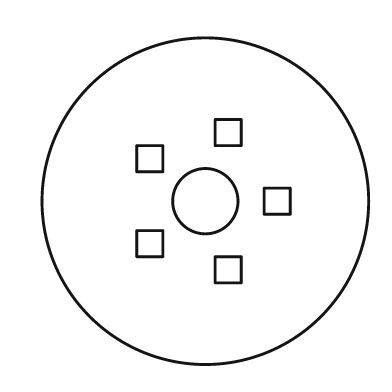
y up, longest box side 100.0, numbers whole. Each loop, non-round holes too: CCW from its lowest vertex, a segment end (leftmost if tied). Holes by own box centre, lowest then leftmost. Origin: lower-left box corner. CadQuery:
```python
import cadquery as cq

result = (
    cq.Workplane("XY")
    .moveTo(50.0, 50.0)
    .circle(50.0)
    .moveTo(53.0, 25.0)
    .lineTo(61.0, 25.0)
    .lineTo(61.0, 33.0)
    .lineTo(53.0, 33.0)
    .close()
    .moveTo(29.0, 33.0)
    .lineTo(37.0, 33.0)
    .lineTo(37.0, 41.0)
    .lineTo(29.0, 41.0)
    .close()
    .moveTo(50.0, 50.0)
    .circle(10.0)
    .moveTo(68.0, 46.0)
    .lineTo(76.0, 46.0)
    .lineTo(76.0, 54.0)
    .lineTo(68.0, 54.0)
    .close()
    .moveTo(29.0, 59.0)
    .lineTo(37.0, 59.0)
    .lineTo(37.0, 67.0)
    .lineTo(29.0, 67.0)
    .close()
    .moveTo(53.0, 67.0)
    .lineTo(61.0, 67.0)
    .lineTo(61.0, 75.0)
    .lineTo(53.0, 75.0)
    .close()
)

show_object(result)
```